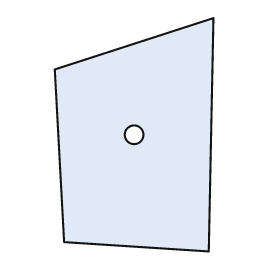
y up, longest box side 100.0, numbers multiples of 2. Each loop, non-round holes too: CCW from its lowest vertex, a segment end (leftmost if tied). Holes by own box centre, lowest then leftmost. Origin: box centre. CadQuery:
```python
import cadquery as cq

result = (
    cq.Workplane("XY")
    .moveTo(32.0, -50.0)
    .lineTo(34.0, 50.0)
    .lineTo(-34.0, 28.0)
    .lineTo(-30.0, -46.0)
    .close()
    .moveTo(0.0, 0.0)
    .circle(4.0)
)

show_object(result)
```